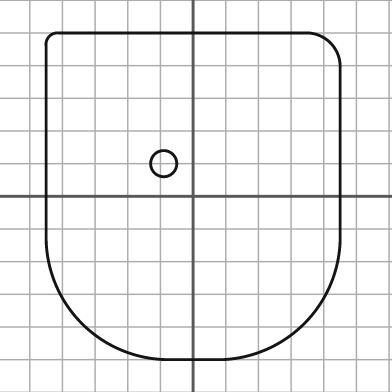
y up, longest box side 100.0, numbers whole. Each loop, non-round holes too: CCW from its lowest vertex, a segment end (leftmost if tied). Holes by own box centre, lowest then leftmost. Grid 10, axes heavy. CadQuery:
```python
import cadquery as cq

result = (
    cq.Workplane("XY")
    .moveTo(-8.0, -50.0)
    .lineTo(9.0, -50.0)
    .threePointArc((34.0, -39.0), (45.0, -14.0))
    .lineTo(45.0, 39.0)
    .threePointArc((42.0, 47.0), (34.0, 50.0))
    .lineTo(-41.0, 50.0)
    .threePointArc((-44.0, 49.0), (-45.0, 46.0))
    .lineTo(-45.0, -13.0)
    .threePointArc((-34.0, -39.0), (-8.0, -50.0))
    .close()
    .moveTo(-9.0, 10.0)
    .circle(4.0)
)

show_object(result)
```